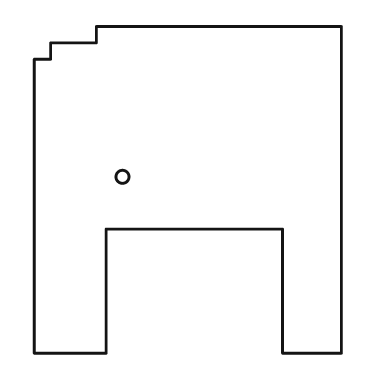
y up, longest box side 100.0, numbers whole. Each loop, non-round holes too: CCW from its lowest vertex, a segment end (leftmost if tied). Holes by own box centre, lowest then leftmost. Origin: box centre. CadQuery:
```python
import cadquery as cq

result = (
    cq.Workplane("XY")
    .moveTo(-47.0, -50.0)
    .lineTo(-25.0, -50.0)
    .lineTo(-25.0, -12.0)
    .lineTo(29.0, -12.0)
    .lineTo(29.0, -50.0)
    .lineTo(47.0, -50.0)
    .lineTo(47.0, 50.0)
    .lineTo(-28.0, 50.0)
    .lineTo(-28.0, 45.0)
    .lineTo(-42.0, 45.0)
    .lineTo(-42.0, 40.0)
    .lineTo(-47.0, 40.0)
    .close()
    .moveTo(-20.0, 4.0)
    .circle(2.0)
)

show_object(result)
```